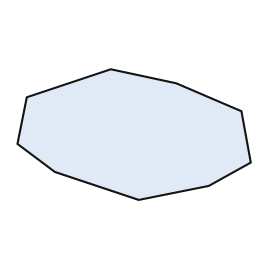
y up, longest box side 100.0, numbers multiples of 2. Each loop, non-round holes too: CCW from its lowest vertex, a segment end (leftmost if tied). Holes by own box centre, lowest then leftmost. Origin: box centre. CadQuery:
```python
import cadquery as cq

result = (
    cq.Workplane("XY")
    .moveTo(2.0, -28.0)
    .lineTo(32.0, -22.0)
    .lineTo(50.0, -12.0)
    .lineTo(46.0, 10.0)
    .lineTo(18.0, 22.0)
    .lineTo(-10.0, 28.0)
    .lineTo(-46.0, 16.0)
    .lineTo(-50.0, -4.0)
    .lineTo(-34.0, -16.0)
    .close()
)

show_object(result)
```